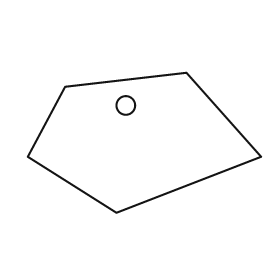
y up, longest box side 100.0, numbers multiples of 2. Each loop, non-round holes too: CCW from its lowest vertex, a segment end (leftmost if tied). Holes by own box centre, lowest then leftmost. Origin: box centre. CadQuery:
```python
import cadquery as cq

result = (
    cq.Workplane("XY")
    .moveTo(-12.0, -30.0)
    .lineTo(50.0, -6.0)
    .lineTo(18.0, 30.0)
    .lineTo(-34.0, 24.0)
    .lineTo(-50.0, -6.0)
    .close()
    .moveTo(-8.0, 16.0)
    .circle(4.0)
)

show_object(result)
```